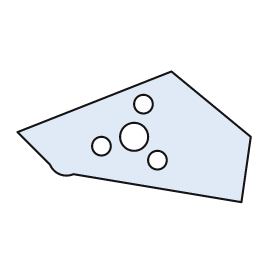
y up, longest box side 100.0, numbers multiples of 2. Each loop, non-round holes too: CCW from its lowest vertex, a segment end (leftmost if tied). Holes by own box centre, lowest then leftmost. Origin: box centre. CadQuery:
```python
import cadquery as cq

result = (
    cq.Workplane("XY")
    .moveTo(46.0, -28.0)
    .lineTo(50.0, 0.0)
    .lineTo(16.0, 28.0)
    .lineTo(-50.0, 2.0)
    .lineTo(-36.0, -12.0)
    .threePointArc((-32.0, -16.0), (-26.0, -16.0))
    .close()
    .moveTo(10.0, -10.0)
    .circle(4.0)
    .moveTo(-14.0, -4.0)
    .circle(4.0)
    .moveTo(0.0, 0.0)
    .circle(6.0)
    .moveTo(4.0, 14.0)
    .circle(4.0)
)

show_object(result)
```